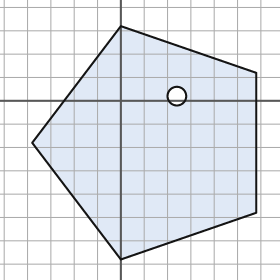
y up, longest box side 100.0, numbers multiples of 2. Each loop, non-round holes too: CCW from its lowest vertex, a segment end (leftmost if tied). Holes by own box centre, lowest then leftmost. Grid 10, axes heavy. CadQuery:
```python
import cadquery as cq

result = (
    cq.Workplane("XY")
    .moveTo(0.0, -68.0)
    .lineTo(58.0, -48.0)
    .lineTo(58.0, 12.0)
    .lineTo(0.0, 32.0)
    .lineTo(-38.0, -18.0)
    .close()
    .moveTo(24.0, 2.0)
    .circle(4.0)
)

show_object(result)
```